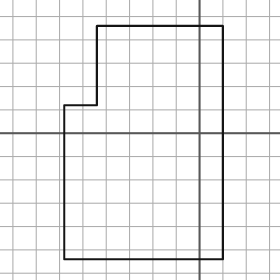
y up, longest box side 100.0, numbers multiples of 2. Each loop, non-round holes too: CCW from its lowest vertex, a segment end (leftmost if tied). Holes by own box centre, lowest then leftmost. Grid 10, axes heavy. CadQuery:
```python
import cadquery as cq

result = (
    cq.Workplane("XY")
    .moveTo(-58.0, -54.0)
    .lineTo(10.0, -54.0)
    .lineTo(10.0, 46.0)
    .lineTo(-44.0, 46.0)
    .lineTo(-44.0, 12.0)
    .lineTo(-58.0, 12.0)
    .close()
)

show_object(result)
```